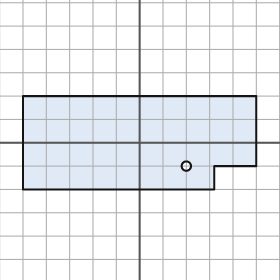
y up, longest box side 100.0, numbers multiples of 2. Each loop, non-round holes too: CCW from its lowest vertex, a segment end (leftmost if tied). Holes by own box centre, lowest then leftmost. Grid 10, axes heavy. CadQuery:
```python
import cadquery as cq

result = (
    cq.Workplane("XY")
    .moveTo(-50.0, -20.0)
    .lineTo(32.0, -20.0)
    .lineTo(32.0, -10.0)
    .lineTo(50.0, -10.0)
    .lineTo(50.0, 20.0)
    .lineTo(-50.0, 20.0)
    .close()
    .moveTo(20.0, -10.0)
    .circle(2.0)
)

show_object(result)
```